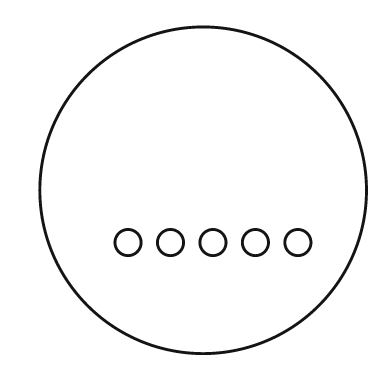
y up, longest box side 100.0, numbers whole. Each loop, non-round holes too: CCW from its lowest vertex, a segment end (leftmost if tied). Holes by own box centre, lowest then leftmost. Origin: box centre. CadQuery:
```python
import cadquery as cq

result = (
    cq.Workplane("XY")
    .moveTo(0.0, 0.0)
    .circle(50.0)
    .moveTo(-23.0, -16.0)
    .circle(4.0)
    .moveTo(-10.0, -16.0)
    .circle(4.0)
    .moveTo(3.0, -16.0)
    .circle(4.0)
    .moveTo(16.0, -16.0)
    .circle(4.0)
    .moveTo(29.0, -16.0)
    .circle(4.0)
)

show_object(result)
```